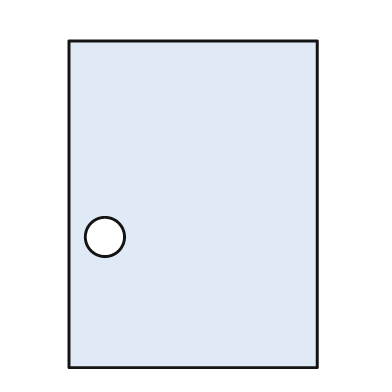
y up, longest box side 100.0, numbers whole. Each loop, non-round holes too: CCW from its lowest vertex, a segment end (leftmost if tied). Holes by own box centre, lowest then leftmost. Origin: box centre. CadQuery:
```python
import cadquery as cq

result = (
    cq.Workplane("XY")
    .moveTo(-38.0, -50.0)
    .lineTo(38.0, -50.0)
    .lineTo(38.0, 50.0)
    .lineTo(-38.0, 50.0)
    .close()
    .moveTo(-27.0, -10.0)
    .circle(6.0)
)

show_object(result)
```